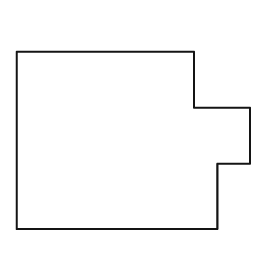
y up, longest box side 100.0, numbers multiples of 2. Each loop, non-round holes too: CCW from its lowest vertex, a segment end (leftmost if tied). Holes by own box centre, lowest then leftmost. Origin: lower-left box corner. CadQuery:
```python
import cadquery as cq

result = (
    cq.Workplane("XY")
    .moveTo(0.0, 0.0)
    .lineTo(86.0, 0.0)
    .lineTo(86.0, 28.0)
    .lineTo(100.0, 28.0)
    .lineTo(100.0, 52.0)
    .lineTo(76.0, 52.0)
    .lineTo(76.0, 76.0)
    .lineTo(0.0, 76.0)
    .close()
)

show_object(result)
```